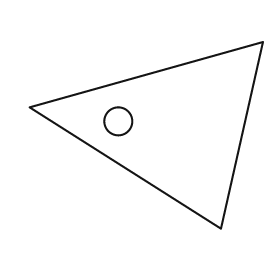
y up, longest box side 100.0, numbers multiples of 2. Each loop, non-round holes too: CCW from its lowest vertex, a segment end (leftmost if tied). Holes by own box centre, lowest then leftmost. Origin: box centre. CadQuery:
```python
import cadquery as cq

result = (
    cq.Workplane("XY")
    .moveTo(32.0, -40.0)
    .lineTo(50.0, 40.0)
    .lineTo(-50.0, 12.0)
    .close()
    .moveTo(-12.0, 6.0)
    .circle(6.0)
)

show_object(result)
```